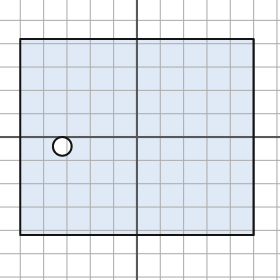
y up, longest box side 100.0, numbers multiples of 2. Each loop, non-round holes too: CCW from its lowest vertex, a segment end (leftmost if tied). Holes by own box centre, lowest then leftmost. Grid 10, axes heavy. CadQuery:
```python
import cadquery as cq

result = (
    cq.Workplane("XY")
    .moveTo(-50.0, -42.0)
    .lineTo(50.0, -42.0)
    .lineTo(50.0, 42.0)
    .lineTo(-50.0, 42.0)
    .close()
    .moveTo(-32.0, -4.0)
    .circle(4.0)
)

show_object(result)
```